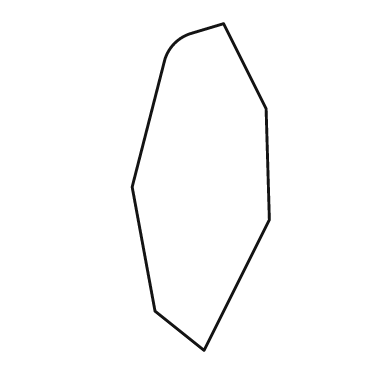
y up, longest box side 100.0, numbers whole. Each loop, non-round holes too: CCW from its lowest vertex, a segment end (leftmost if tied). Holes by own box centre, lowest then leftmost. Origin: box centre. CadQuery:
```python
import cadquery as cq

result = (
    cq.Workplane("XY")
    .moveTo(1.0, -50.0)
    .lineTo(21.0, -10.0)
    .lineTo(20.0, 24.0)
    .lineTo(7.0, 50.0)
    .lineTo(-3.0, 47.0)
    .threePointArc((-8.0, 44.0), (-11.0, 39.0))
    .lineTo(-21.0, 0.0)
    .lineTo(-14.0, -38.0)
    .close()
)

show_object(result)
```